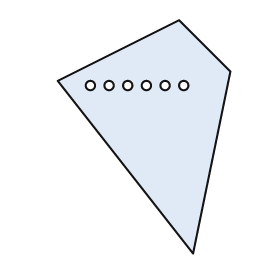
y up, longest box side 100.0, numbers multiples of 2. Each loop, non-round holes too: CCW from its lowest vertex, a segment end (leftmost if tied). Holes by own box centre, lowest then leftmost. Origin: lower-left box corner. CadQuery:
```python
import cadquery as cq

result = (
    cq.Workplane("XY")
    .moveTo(58.0, 0.0)
    .lineTo(74.0, 78.0)
    .lineTo(52.0, 100.0)
    .lineTo(0.0, 74.0)
    .close()
    .moveTo(14.0, 72.0)
    .circle(2.0)
    .moveTo(22.0, 72.0)
    .circle(2.0)
    .moveTo(30.0, 72.0)
    .circle(2.0)
    .moveTo(38.0, 72.0)
    .circle(2.0)
    .moveTo(46.0, 72.0)
    .circle(2.0)
    .moveTo(54.0, 72.0)
    .circle(2.0)
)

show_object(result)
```